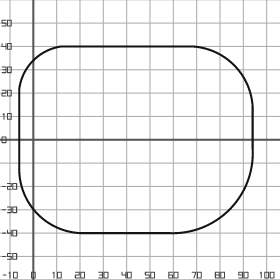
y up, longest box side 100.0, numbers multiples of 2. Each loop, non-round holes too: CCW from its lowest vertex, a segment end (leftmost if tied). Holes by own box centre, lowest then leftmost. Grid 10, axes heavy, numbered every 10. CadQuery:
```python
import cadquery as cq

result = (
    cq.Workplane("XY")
    .moveTo(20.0, -40.0)
    .lineTo(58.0, -40.0)
    .threePointArc((84.0, -30.0), (94.0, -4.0))
    .lineTo(94.0, 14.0)
    .threePointArc((86.0, 32.0), (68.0, 40.0))
    .lineTo(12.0, 40.0)
    .threePointArc((0.0, 34.0), (-6.0, 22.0))
    .lineTo(-6.0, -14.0)
    .threePointArc((2.0, -32.0), (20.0, -40.0))
    .close()
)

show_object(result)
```